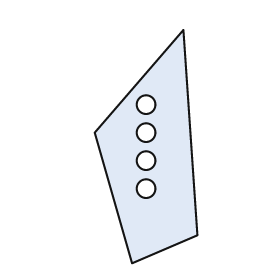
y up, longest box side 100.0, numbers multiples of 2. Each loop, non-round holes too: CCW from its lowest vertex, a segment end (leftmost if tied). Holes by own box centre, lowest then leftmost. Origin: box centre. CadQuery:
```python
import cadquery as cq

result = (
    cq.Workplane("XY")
    .moveTo(-6.0, -50.0)
    .lineTo(22.0, -38.0)
    .lineTo(16.0, 50.0)
    .lineTo(-22.0, 6.0)
    .close()
    .moveTo(0.0, -18.0)
    .circle(4.0)
    .moveTo(0.0, -6.0)
    .circle(4.0)
    .moveTo(0.0, 6.0)
    .circle(4.0)
    .moveTo(0.0, 18.0)
    .circle(4.0)
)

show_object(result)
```